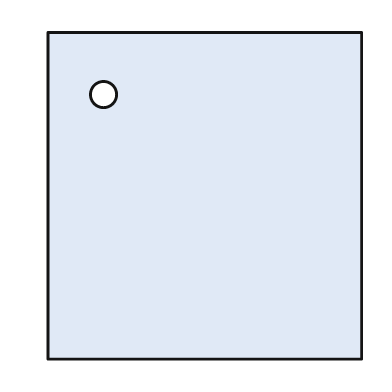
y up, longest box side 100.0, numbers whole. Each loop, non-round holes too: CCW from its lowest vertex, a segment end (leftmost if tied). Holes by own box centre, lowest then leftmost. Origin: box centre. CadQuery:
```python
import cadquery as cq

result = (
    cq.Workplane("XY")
    .moveTo(-48.0, -50.0)
    .lineTo(48.0, -50.0)
    .lineTo(48.0, 50.0)
    .lineTo(-48.0, 50.0)
    .close()
    .moveTo(-31.0, 31.0)
    .circle(4.0)
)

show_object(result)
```